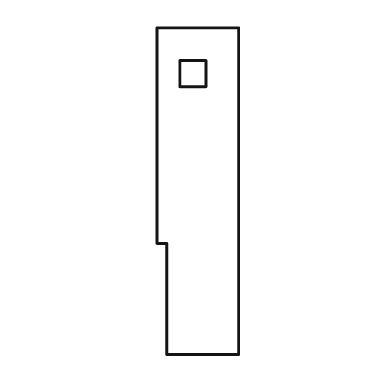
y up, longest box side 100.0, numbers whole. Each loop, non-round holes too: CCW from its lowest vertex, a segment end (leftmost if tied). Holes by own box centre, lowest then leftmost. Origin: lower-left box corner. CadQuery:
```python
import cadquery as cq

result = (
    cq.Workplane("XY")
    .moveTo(3.0, 0.0)
    .lineTo(25.0, 0.0)
    .lineTo(25.0, 100.0)
    .lineTo(0.0, 100.0)
    .lineTo(0.0, 34.0)
    .lineTo(3.0, 34.0)
    .close()
    .moveTo(7.0, 82.0)
    .lineTo(15.0, 82.0)
    .lineTo(15.0, 90.0)
    .lineTo(7.0, 90.0)
    .close()
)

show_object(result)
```